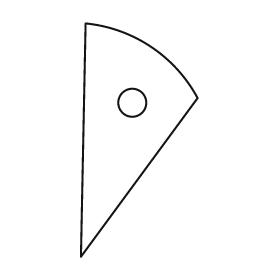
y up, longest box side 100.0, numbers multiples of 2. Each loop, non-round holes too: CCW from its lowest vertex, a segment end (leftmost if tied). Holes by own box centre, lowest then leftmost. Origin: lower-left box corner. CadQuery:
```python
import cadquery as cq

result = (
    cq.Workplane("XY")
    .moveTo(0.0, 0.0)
    .lineTo(50.0, 68.0)
    .threePointArc((30.0, 90.0), (2.0, 100.0))
    .close()
    .moveTo(22.0, 66.0)
    .circle(6.0)
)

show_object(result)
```